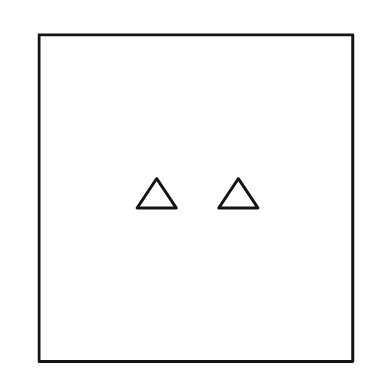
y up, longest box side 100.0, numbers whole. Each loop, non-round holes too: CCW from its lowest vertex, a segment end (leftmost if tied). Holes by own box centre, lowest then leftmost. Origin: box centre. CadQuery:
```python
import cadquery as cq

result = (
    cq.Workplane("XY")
    .moveTo(-48.0, -50.0)
    .lineTo(48.0, -50.0)
    .lineTo(48.0, 50.0)
    .lineTo(-48.0, 50.0)
    .close()
    .moveTo(-18.0, -3.0)
    .lineTo(-6.0, -3.0)
    .lineTo(-12.0, 6.0)
    .close()
    .moveTo(7.0, -3.0)
    .lineTo(19.0, -3.0)
    .lineTo(13.0, 6.0)
    .close()
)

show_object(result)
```